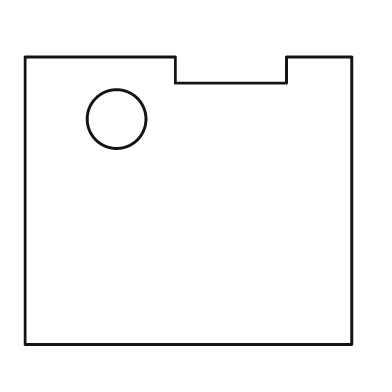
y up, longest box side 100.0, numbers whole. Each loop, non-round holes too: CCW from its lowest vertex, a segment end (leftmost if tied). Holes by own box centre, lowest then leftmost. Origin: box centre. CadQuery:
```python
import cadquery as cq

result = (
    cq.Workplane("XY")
    .moveTo(-50.0, -44.0)
    .lineTo(50.0, -44.0)
    .lineTo(50.0, 44.0)
    .lineTo(30.0, 44.0)
    .lineTo(30.0, 36.0)
    .lineTo(-4.0, 36.0)
    .lineTo(-4.0, 44.0)
    .lineTo(-50.0, 44.0)
    .close()
    .moveTo(-22.0, 25.0)
    .circle(9.0)
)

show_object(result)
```